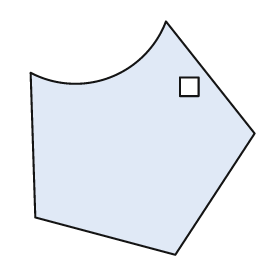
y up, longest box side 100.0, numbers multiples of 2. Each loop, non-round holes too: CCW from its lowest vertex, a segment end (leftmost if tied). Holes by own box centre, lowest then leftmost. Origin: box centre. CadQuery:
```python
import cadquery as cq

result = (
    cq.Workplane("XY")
    .moveTo(14.0, -50.0)
    .lineTo(48.0, 2.0)
    .lineTo(10.0, 50.0)
    .threePointArc((-14.0, 26.0), (-48.0, 28.0))
    .lineTo(-46.0, -34.0)
    .close()
    .moveTo(16.0, 18.0)
    .lineTo(24.0, 18.0)
    .lineTo(24.0, 26.0)
    .lineTo(16.0, 26.0)
    .close()
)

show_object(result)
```